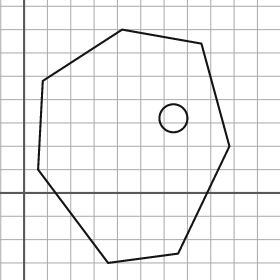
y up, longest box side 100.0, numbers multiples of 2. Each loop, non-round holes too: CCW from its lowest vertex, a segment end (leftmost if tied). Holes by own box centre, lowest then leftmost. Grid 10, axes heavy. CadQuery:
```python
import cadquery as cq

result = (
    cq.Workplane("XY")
    .moveTo(36.0, -30.0)
    .lineTo(66.0, -26.0)
    .lineTo(88.0, 20.0)
    .lineTo(76.0, 64.0)
    .lineTo(42.0, 70.0)
    .lineTo(8.0, 48.0)
    .lineTo(6.0, 10.0)
    .close()
    .moveTo(64.0, 32.0)
    .circle(6.0)
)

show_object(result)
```